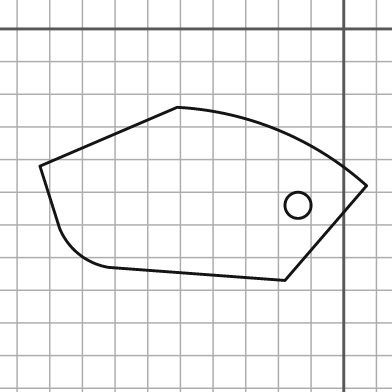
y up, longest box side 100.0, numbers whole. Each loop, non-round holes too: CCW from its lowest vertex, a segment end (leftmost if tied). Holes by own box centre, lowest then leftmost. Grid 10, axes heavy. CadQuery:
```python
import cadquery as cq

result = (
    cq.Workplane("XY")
    .moveTo(-18.0, -77.0)
    .lineTo(7.0, -48.0)
    .threePointArc((-20.0, -31.0), (-51.0, -24.0))
    .lineTo(-93.0, -42.0)
    .lineTo(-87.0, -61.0)
    .threePointArc((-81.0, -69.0), (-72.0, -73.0))
    .close()
    .moveTo(-14.0, -54.0)
    .circle(4.0)
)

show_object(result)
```